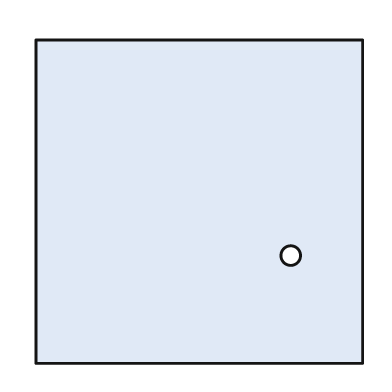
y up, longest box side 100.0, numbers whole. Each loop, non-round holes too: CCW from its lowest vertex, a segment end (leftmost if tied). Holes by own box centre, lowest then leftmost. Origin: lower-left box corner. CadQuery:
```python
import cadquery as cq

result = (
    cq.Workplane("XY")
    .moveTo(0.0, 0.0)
    .lineTo(100.0, 0.0)
    .lineTo(100.0, 99.0)
    .lineTo(0.0, 99.0)
    .close()
    .moveTo(78.0, 33.0)
    .circle(3.0)
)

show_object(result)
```